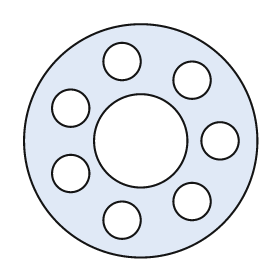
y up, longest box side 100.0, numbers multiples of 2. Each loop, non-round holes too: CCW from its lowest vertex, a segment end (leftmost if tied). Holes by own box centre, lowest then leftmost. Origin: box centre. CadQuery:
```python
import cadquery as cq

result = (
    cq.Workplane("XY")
    .moveTo(0.0, 0.0)
    .circle(50.0)
    .moveTo(-8.0, -34.0)
    .circle(8.0)
    .moveTo(22.0, -26.0)
    .circle(8.0)
    .moveTo(-30.0, -14.0)
    .circle(8.0)
    .moveTo(0.0, 0.0)
    .circle(20.0)
    .moveTo(34.0, 0.0)
    .circle(8.0)
    .moveTo(-30.0, 14.0)
    .circle(8.0)
    .moveTo(22.0, 26.0)
    .circle(8.0)
    .moveTo(-8.0, 34.0)
    .circle(8.0)
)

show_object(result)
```